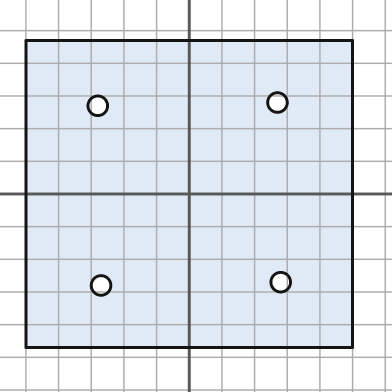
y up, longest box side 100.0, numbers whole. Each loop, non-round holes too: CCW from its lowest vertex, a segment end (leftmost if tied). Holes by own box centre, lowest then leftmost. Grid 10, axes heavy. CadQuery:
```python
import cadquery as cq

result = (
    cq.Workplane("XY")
    .moveTo(-50.0, -47.0)
    .lineTo(50.0, -47.0)
    .lineTo(50.0, 47.0)
    .lineTo(-50.0, 47.0)
    .close()
    .moveTo(-27.0, -28.0)
    .circle(3.0)
    .moveTo(28.0, -27.0)
    .circle(3.0)
    .moveTo(-28.0, 27.0)
    .circle(3.0)
    .moveTo(27.0, 28.0)
    .circle(3.0)
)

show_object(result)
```